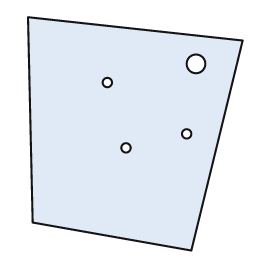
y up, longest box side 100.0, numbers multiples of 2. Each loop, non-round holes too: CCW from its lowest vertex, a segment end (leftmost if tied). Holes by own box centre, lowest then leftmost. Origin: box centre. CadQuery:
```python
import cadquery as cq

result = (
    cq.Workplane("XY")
    .moveTo(24.0, -50.0)
    .lineTo(46.0, 40.0)
    .lineTo(-46.0, 50.0)
    .lineTo(-44.0, -38.0)
    .close()
    .moveTo(-4.0, -6.0)
    .circle(2.0)
    .moveTo(22.0, 0.0)
    .circle(2.0)
    .moveTo(-12.0, 22.0)
    .circle(2.0)
    .moveTo(26.0, 30.0)
    .circle(4.0)
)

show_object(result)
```